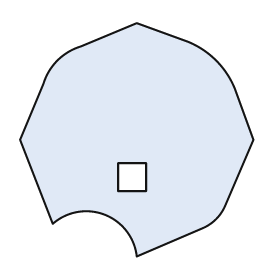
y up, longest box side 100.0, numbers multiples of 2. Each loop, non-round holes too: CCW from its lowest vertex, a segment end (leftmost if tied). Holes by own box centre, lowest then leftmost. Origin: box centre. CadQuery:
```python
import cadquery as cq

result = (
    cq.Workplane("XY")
    .moveTo(0.0, -50.0)
    .lineTo(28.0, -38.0)
    .threePointArc((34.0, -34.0), (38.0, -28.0))
    .lineTo(50.0, 0.0)
    .lineTo(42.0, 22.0)
    .threePointArc((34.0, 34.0), (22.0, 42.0))
    .lineTo(0.0, 50.0)
    .lineTo(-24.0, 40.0)
    .threePointArc((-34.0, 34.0), (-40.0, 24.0))
    .lineTo(-50.0, 0.0)
    .lineTo(-36.0, -36.0)
    .threePointArc((-14.0, -32.0), (0.0, -50.0))
    .close()
    .moveTo(-8.0, -22.0)
    .lineTo(4.0, -22.0)
    .lineTo(4.0, -10.0)
    .lineTo(-8.0, -10.0)
    .close()
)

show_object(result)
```